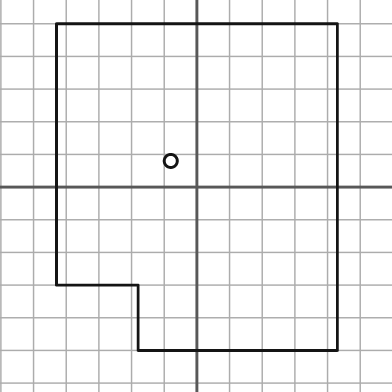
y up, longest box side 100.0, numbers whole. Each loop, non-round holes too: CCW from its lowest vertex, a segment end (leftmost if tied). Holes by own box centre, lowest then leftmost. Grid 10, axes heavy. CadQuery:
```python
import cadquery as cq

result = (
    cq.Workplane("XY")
    .moveTo(-18.0, -50.0)
    .lineTo(43.0, -50.0)
    .lineTo(43.0, 50.0)
    .lineTo(-43.0, 50.0)
    .lineTo(-43.0, -30.0)
    .lineTo(-18.0, -30.0)
    .close()
    .moveTo(-8.0, 8.0)
    .circle(2.0)
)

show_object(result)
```